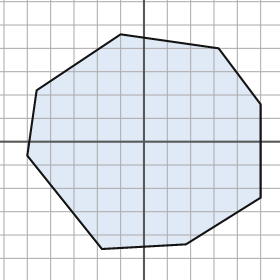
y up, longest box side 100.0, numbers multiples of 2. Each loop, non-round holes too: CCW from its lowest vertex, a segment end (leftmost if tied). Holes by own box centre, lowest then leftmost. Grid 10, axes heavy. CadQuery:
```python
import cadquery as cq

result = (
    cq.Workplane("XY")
    .moveTo(-18.0, -46.0)
    .lineTo(18.0, -44.0)
    .lineTo(50.0, -24.0)
    .lineTo(50.0, 16.0)
    .lineTo(32.0, 40.0)
    .lineTo(-10.0, 46.0)
    .lineTo(-46.0, 22.0)
    .lineTo(-50.0, -6.0)
    .close()
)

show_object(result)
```